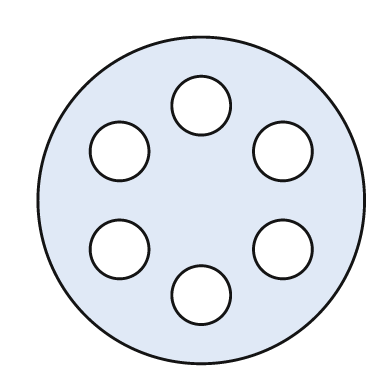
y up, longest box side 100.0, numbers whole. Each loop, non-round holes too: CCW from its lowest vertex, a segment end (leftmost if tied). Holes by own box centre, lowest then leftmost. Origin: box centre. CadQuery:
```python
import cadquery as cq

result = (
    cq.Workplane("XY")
    .moveTo(0.0, 0.0)
    .circle(50.0)
    .moveTo(0.0, -29.0)
    .circle(9.0)
    .moveTo(-25.0, -15.0)
    .circle(9.0)
    .moveTo(25.0, -15.0)
    .circle(9.0)
    .moveTo(-25.0, 15.0)
    .circle(9.0)
    .moveTo(25.0, 15.0)
    .circle(9.0)
    .moveTo(0.0, 29.0)
    .circle(9.0)
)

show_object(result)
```